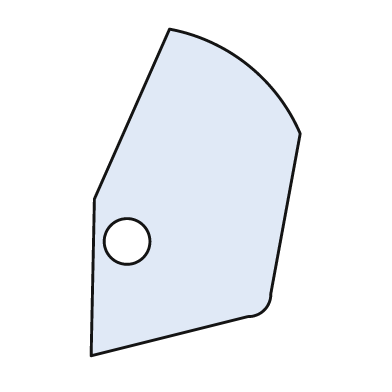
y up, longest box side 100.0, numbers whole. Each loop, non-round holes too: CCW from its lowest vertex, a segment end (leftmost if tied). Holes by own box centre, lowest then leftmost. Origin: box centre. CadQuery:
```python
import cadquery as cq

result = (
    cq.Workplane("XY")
    .moveTo(-32.0, -50.0)
    .lineTo(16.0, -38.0)
    .threePointArc((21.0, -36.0), (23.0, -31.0))
    .lineTo(32.0, 18.0)
    .threePointArc((16.0, 39.0), (-8.0, 50.0))
    .lineTo(-31.0, -2.0)
    .close()
    .moveTo(-21.0, -15.0)
    .circle(7.0)
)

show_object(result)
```